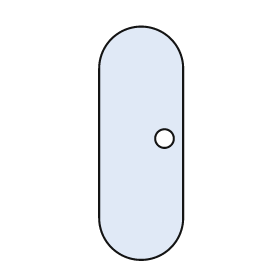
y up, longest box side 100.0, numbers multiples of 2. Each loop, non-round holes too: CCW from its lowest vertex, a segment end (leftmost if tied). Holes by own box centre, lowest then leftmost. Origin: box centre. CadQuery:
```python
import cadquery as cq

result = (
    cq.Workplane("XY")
    .moveTo(-18.0, -32.0)
    .threePointArc((0.0, -50.0), (18.0, -32.0))
    .lineTo(18.0, 32.0)
    .threePointArc((0.0, 50.0), (-18.0, 32.0))
    .close()
    .moveTo(10.0, 2.0)
    .circle(4.0)
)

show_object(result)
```